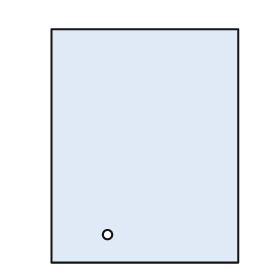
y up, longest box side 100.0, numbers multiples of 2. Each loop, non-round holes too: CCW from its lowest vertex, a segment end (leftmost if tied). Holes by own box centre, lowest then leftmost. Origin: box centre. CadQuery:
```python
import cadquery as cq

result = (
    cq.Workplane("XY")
    .moveTo(-40.0, -50.0)
    .lineTo(40.0, -50.0)
    .lineTo(40.0, 50.0)
    .lineTo(-40.0, 50.0)
    .close()
    .moveTo(-16.0, -38.0)
    .circle(2.0)
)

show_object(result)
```